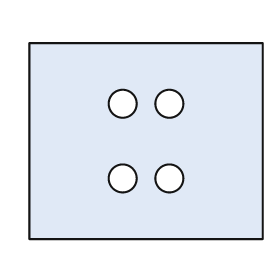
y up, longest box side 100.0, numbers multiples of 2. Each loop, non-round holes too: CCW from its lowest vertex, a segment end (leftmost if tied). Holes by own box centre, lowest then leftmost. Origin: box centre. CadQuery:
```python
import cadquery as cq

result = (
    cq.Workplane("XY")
    .moveTo(-50.0, -42.0)
    .lineTo(50.0, -42.0)
    .lineTo(50.0, 42.0)
    .lineTo(-50.0, 42.0)
    .close()
    .moveTo(-10.0, -16.0)
    .circle(6.0)
    .moveTo(10.0, -16.0)
    .circle(6.0)
    .moveTo(-10.0, 16.0)
    .circle(6.0)
    .moveTo(10.0, 16.0)
    .circle(6.0)
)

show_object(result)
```